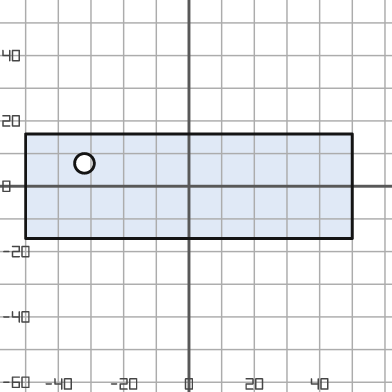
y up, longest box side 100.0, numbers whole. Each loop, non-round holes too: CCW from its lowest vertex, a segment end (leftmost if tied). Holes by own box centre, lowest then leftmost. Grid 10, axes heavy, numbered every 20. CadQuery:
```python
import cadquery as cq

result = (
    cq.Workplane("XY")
    .moveTo(-50.0, -16.0)
    .lineTo(50.0, -16.0)
    .lineTo(50.0, 16.0)
    .lineTo(-50.0, 16.0)
    .close()
    .moveTo(-32.0, 7.0)
    .circle(3.0)
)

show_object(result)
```